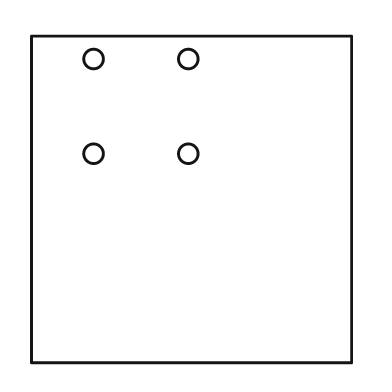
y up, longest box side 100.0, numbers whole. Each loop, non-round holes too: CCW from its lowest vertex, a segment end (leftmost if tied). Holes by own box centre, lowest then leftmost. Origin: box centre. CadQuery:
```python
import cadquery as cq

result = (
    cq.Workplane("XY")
    .moveTo(-49.0, -50.0)
    .lineTo(49.0, -50.0)
    .lineTo(49.0, 50.0)
    .lineTo(-49.0, 50.0)
    .close()
    .moveTo(-30.0, 14.0)
    .circle(3.0)
    .moveTo(-1.0, 14.0)
    .circle(3.0)
    .moveTo(-30.0, 43.0)
    .circle(3.0)
    .moveTo(-1.0, 43.0)
    .circle(3.0)
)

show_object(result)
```